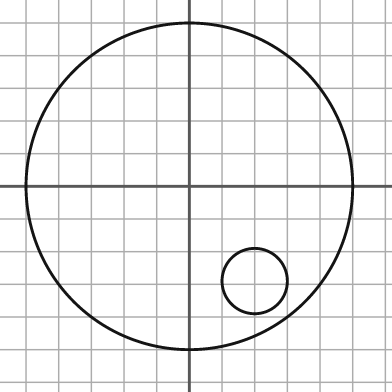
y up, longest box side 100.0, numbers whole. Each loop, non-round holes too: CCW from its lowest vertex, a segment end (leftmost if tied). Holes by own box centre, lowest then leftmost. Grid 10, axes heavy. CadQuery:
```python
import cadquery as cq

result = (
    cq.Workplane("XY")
    .moveTo(0.0, 0.0)
    .circle(50.0)
    .moveTo(20.0, -29.0)
    .circle(10.0)
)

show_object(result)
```